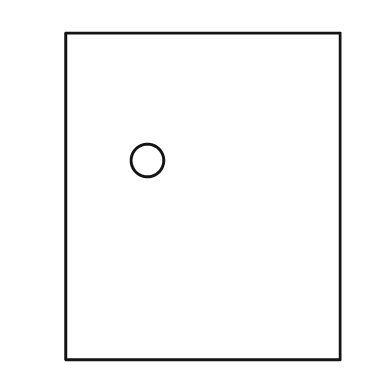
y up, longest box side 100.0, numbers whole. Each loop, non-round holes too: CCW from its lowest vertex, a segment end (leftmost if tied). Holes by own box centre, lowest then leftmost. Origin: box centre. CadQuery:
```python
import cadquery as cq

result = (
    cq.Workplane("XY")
    .moveTo(-42.0, -50.0)
    .lineTo(42.0, -50.0)
    .lineTo(42.0, 50.0)
    .lineTo(-42.0, 50.0)
    .close()
    .moveTo(-17.0, 11.0)
    .circle(5.0)
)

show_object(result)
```